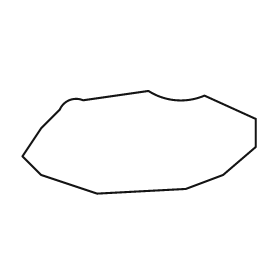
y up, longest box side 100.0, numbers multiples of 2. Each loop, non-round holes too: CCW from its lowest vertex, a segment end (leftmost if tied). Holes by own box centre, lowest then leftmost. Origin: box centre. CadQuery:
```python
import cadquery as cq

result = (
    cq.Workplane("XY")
    .moveTo(-18.0, -22.0)
    .lineTo(20.0, -20.0)
    .lineTo(36.0, -14.0)
    .lineTo(50.0, -2.0)
    .lineTo(50.0, 10.0)
    .lineTo(28.0, 20.0)
    .threePointArc((16.0, 18.0), (4.0, 22.0))
    .lineTo(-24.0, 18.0)
    .threePointArc((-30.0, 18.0), (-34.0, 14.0))
    .lineTo(-42.0, 6.0)
    .lineTo(-50.0, -6.0)
    .lineTo(-42.0, -14.0)
    .close()
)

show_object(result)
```